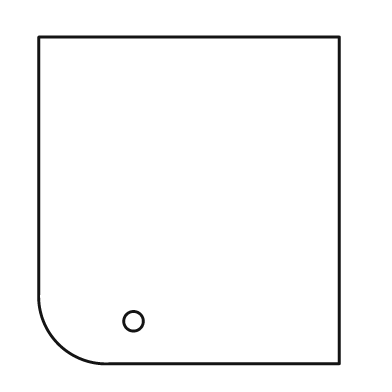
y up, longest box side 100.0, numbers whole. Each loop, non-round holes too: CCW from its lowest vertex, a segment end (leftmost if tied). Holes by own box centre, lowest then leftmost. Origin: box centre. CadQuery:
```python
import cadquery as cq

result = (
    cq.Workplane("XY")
    .moveTo(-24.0, -50.0)
    .lineTo(46.0, -50.0)
    .lineTo(46.0, 50.0)
    .lineTo(-46.0, 50.0)
    .lineTo(-46.0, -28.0)
    .threePointArc((-40.0, -44.0), (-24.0, -50.0))
    .close()
    .moveTo(-17.0, -37.0)
    .circle(3.0)
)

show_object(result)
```